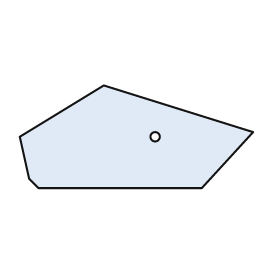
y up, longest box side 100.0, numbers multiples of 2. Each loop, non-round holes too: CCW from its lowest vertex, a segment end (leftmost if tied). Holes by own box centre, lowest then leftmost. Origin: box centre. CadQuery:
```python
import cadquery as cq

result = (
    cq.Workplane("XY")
    .moveTo(-42.0, -22.0)
    .lineTo(28.0, -22.0)
    .lineTo(50.0, 2.0)
    .lineTo(-14.0, 22.0)
    .lineTo(-50.0, 0.0)
    .lineTo(-46.0, -18.0)
    .close()
    .moveTo(8.0, 0.0)
    .circle(2.0)
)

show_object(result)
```